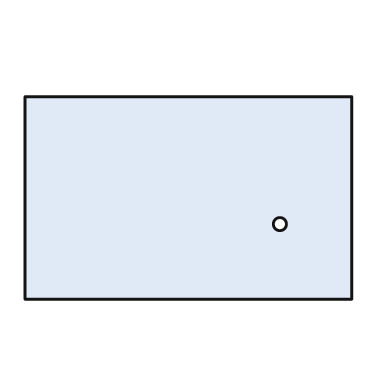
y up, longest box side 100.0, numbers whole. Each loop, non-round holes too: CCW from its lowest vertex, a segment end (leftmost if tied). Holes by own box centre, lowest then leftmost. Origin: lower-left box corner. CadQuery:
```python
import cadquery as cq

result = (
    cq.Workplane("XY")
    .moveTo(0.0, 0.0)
    .lineTo(100.0, 0.0)
    .lineTo(100.0, 62.0)
    .lineTo(0.0, 62.0)
    .close()
    .moveTo(78.0, 23.0)
    .circle(2.0)
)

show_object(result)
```